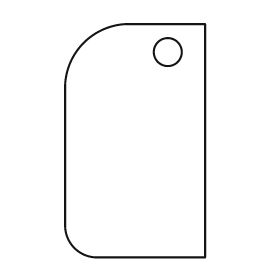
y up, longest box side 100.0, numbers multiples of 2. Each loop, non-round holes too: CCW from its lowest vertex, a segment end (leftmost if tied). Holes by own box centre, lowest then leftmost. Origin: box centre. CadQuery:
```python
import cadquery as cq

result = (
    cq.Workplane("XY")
    .moveTo(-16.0, -50.0)
    .lineTo(30.0, -50.0)
    .lineTo(30.0, 50.0)
    .lineTo(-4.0, 50.0)
    .threePointArc((-22.0, 42.0), (-30.0, 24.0))
    .lineTo(-30.0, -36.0)
    .threePointArc((-26.0, -46.0), (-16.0, -50.0))
    .close()
    .moveTo(14.0, 38.0)
    .circle(6.0)
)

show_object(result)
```